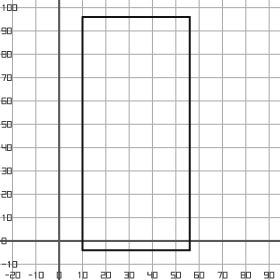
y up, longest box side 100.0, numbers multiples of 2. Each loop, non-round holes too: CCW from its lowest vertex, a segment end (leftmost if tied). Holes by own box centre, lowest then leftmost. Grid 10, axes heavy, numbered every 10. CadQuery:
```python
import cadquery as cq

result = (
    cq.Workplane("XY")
    .moveTo(10.0, -4.0)
    .lineTo(56.0, -4.0)
    .lineTo(56.0, 96.0)
    .lineTo(10.0, 96.0)
    .close()
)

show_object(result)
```